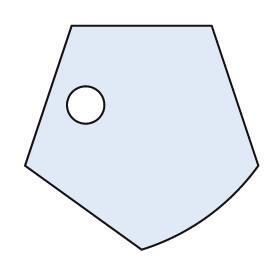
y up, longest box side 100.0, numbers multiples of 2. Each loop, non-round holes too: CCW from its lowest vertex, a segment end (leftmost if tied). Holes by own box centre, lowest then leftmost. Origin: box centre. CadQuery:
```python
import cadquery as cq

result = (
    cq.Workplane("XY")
    .moveTo(0.0, -48.0)
    .threePointArc((28.0, -34.0), (50.0, -12.0))
    .lineTo(30.0, 48.0)
    .lineTo(-30.0, 48.0)
    .lineTo(-50.0, -12.0)
    .close()
    .moveTo(-24.0, 14.0)
    .circle(8.0)
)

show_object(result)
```